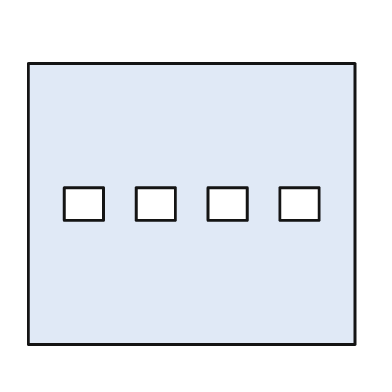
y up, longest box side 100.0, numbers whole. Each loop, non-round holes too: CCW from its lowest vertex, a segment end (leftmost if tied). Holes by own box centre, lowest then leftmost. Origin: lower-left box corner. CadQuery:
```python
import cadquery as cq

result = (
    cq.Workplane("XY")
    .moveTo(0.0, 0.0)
    .lineTo(100.0, 0.0)
    .lineTo(100.0, 86.0)
    .lineTo(0.0, 86.0)
    .close()
    .moveTo(11.0, 38.0)
    .lineTo(23.0, 38.0)
    .lineTo(23.0, 48.0)
    .lineTo(11.0, 48.0)
    .close()
    .moveTo(33.0, 38.0)
    .lineTo(45.0, 38.0)
    .lineTo(45.0, 48.0)
    .lineTo(33.0, 48.0)
    .close()
    .moveTo(55.0, 38.0)
    .lineTo(67.0, 38.0)
    .lineTo(67.0, 48.0)
    .lineTo(55.0, 48.0)
    .close()
    .moveTo(77.0, 38.0)
    .lineTo(89.0, 38.0)
    .lineTo(89.0, 48.0)
    .lineTo(77.0, 48.0)
    .close()
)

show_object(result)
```